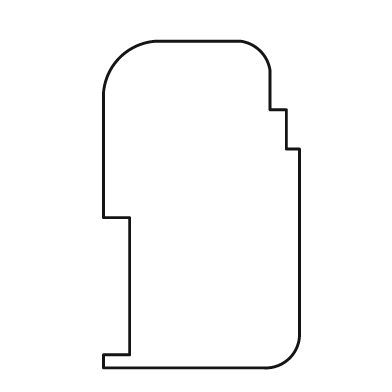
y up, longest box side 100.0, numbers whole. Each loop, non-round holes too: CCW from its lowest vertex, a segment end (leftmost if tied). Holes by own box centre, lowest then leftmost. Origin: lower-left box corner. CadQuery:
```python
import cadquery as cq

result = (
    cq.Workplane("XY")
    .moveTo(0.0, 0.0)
    .lineTo(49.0, 0.0)
    .threePointArc((57.0, 3.0), (60.0, 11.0))
    .lineTo(60.0, 67.0)
    .lineTo(56.0, 67.0)
    .lineTo(56.0, 79.0)
    .lineTo(51.0, 79.0)
    .lineTo(51.0, 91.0)
    .threePointArc((48.0, 97.0), (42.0, 100.0))
    .lineTo(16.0, 100.0)
    .threePointArc((5.0, 95.0), (0.0, 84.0))
    .lineTo(0.0, 46.0)
    .lineTo(8.0, 46.0)
    .lineTo(8.0, 4.0)
    .lineTo(0.0, 4.0)
    .close()
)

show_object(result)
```